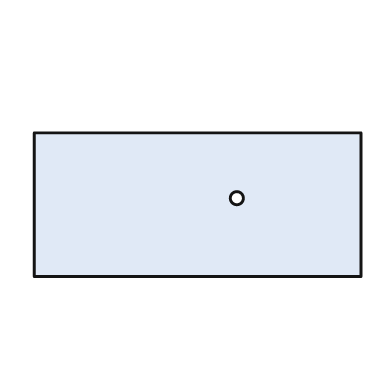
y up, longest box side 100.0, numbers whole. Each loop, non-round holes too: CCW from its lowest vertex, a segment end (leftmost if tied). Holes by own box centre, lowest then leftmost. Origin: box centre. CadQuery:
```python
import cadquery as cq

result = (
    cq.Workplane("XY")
    .moveTo(-50.0, -22.0)
    .lineTo(50.0, -22.0)
    .lineTo(50.0, 22.0)
    .lineTo(-50.0, 22.0)
    .close()
    .moveTo(12.0, 2.0)
    .circle(2.0)
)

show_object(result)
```